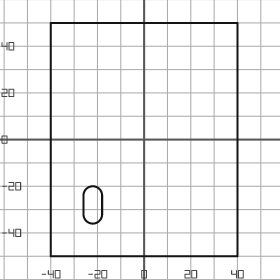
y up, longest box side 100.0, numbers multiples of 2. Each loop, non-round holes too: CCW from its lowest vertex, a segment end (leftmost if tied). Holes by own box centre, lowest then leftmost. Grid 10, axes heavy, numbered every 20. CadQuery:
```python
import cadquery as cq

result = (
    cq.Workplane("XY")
    .moveTo(-40.0, -50.0)
    .lineTo(40.0, -50.0)
    .lineTo(40.0, 50.0)
    .lineTo(-40.0, 50.0)
    .close()
    .moveTo(-26.0, -32.0)
    .threePointArc((-22.0, -36.0), (-18.0, -32.0))
    .lineTo(-18.0, -24.0)
    .threePointArc((-22.0, -20.0), (-26.0, -24.0))
    .close()
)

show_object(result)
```